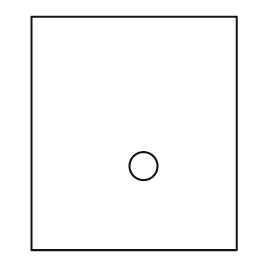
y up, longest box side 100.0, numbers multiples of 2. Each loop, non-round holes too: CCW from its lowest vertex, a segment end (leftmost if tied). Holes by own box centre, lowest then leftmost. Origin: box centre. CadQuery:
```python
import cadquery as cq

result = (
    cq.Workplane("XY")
    .moveTo(-44.0, -50.0)
    .lineTo(44.0, -50.0)
    .lineTo(44.0, 50.0)
    .lineTo(-44.0, 50.0)
    .close()
    .moveTo(4.0, -14.0)
    .circle(6.0)
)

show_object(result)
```